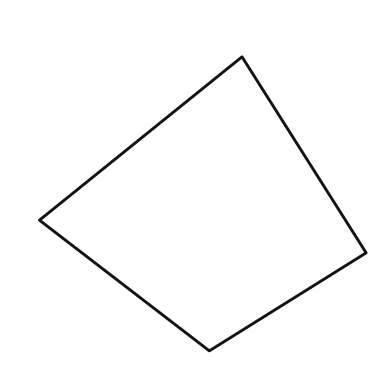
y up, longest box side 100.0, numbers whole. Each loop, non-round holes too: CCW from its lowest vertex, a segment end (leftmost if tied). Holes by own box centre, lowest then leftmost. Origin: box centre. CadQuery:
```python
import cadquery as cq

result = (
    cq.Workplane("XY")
    .moveTo(2.0, -45.0)
    .lineTo(50.0, -15.0)
    .lineTo(12.0, 45.0)
    .lineTo(-50.0, -5.0)
    .close()
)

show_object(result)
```